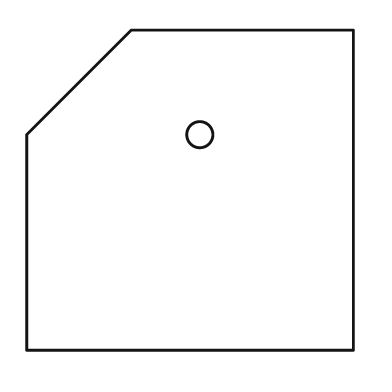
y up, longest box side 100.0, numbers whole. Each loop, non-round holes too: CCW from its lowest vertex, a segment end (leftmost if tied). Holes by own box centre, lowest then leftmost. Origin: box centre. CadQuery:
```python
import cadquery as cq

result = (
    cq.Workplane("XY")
    .moveTo(-50.0, -49.0)
    .lineTo(50.0, -49.0)
    .lineTo(50.0, 49.0)
    .lineTo(-18.0, 49.0)
    .lineTo(-50.0, 17.0)
    .close()
    .moveTo(3.0, 17.0)
    .circle(4.0)
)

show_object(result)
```